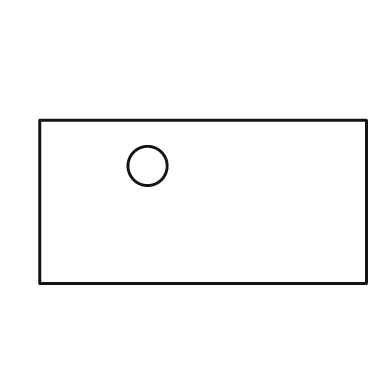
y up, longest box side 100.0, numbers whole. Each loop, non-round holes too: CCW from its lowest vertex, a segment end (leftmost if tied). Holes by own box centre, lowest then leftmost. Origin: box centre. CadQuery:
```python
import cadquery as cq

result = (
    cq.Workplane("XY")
    .moveTo(-50.0, -25.0)
    .lineTo(50.0, -25.0)
    .lineTo(50.0, 25.0)
    .lineTo(-50.0, 25.0)
    .close()
    .moveTo(-17.0, 11.0)
    .circle(6.0)
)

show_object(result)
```